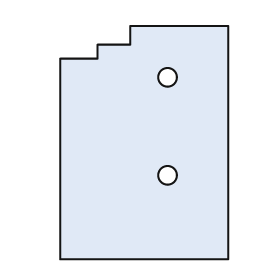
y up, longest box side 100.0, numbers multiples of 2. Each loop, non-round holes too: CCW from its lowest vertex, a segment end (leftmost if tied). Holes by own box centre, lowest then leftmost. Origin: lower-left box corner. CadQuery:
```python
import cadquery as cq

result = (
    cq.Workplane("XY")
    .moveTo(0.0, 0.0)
    .lineTo(72.0, 0.0)
    .lineTo(72.0, 100.0)
    .lineTo(30.0, 100.0)
    .lineTo(30.0, 92.0)
    .lineTo(16.0, 92.0)
    .lineTo(16.0, 86.0)
    .lineTo(0.0, 86.0)
    .close()
    .moveTo(46.0, 36.0)
    .circle(4.0)
    .moveTo(46.0, 78.0)
    .circle(4.0)
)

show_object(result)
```